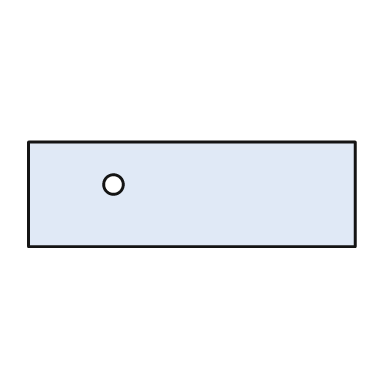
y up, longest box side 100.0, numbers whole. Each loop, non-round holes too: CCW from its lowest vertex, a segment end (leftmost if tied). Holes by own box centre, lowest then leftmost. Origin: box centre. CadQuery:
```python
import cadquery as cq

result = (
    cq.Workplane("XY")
    .moveTo(-50.0, -16.0)
    .lineTo(50.0, -16.0)
    .lineTo(50.0, 16.0)
    .lineTo(-50.0, 16.0)
    .close()
    .moveTo(-24.0, 3.0)
    .circle(3.0)
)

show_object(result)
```